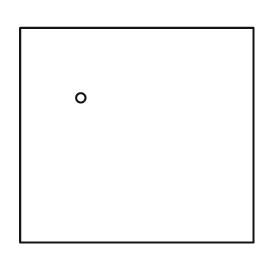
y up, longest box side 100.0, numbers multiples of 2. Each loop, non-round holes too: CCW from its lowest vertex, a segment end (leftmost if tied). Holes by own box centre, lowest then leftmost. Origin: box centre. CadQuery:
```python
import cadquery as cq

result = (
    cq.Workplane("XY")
    .moveTo(-50.0, -46.0)
    .lineTo(50.0, -46.0)
    .lineTo(50.0, 46.0)
    .lineTo(-50.0, 46.0)
    .close()
    .moveTo(-24.0, 16.0)
    .circle(2.0)
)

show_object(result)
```